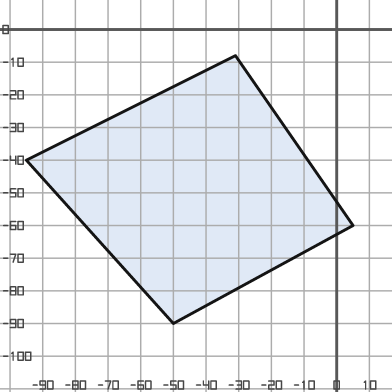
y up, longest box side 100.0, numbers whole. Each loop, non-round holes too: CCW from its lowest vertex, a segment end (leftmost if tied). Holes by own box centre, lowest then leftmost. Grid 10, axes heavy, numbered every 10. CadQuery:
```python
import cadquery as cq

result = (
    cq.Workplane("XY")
    .moveTo(-50.0, -90.0)
    .lineTo(5.0, -60.0)
    .lineTo(-31.0, -8.0)
    .lineTo(-95.0, -40.0)
    .close()
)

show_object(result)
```